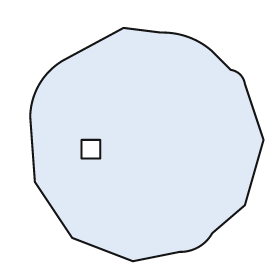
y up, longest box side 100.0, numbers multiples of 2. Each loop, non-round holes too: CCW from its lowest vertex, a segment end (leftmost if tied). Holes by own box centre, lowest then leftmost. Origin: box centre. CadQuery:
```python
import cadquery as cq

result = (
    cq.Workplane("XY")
    .moveTo(-6.0, -50.0)
    .lineTo(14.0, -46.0)
    .threePointArc((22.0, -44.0), (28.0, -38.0))
    .lineTo(42.0, -26.0)
    .lineTo(50.0, 2.0)
    .lineTo(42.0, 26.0)
    .threePointArc((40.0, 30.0), (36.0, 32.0))
    .lineTo(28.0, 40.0)
    .threePointArc((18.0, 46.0), (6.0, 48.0))
    .lineTo(-10.0, 50.0)
    .lineTo(-36.0, 36.0)
    .threePointArc((-46.0, 26.0), (-50.0, 12.0))
    .lineTo(-48.0, -16.0)
    .lineTo(-32.0, -40.0)
    .close()
    .moveTo(-28.0, -6.0)
    .lineTo(-20.0, -6.0)
    .lineTo(-20.0, 2.0)
    .lineTo(-28.0, 2.0)
    .close()
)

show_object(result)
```